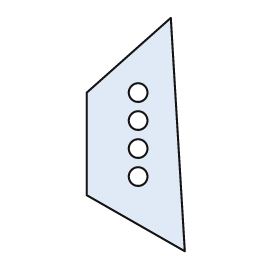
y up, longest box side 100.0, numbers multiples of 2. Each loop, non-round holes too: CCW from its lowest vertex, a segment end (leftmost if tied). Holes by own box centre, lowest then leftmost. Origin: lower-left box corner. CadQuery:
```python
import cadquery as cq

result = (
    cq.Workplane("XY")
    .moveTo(42.0, 0.0)
    .lineTo(36.0, 100.0)
    .lineTo(0.0, 68.0)
    .lineTo(0.0, 24.0)
    .close()
    .moveTo(22.0, 32.0)
    .circle(4.0)
    .moveTo(22.0, 44.0)
    .circle(4.0)
    .moveTo(22.0, 56.0)
    .circle(4.0)
    .moveTo(22.0, 68.0)
    .circle(4.0)
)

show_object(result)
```